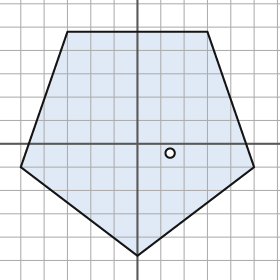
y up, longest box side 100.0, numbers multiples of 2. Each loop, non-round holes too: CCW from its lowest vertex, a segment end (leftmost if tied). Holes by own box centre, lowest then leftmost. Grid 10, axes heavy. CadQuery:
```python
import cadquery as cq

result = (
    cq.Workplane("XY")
    .moveTo(0.0, -48.0)
    .lineTo(50.0, -10.0)
    .lineTo(30.0, 48.0)
    .lineTo(-30.0, 48.0)
    .lineTo(-50.0, -10.0)
    .close()
    .moveTo(14.0, -4.0)
    .circle(2.0)
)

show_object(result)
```